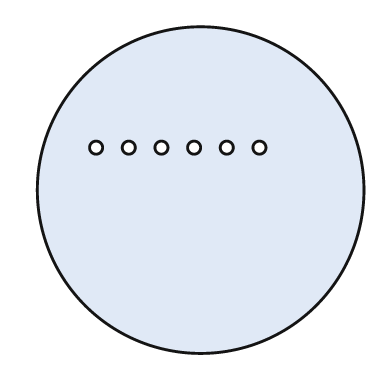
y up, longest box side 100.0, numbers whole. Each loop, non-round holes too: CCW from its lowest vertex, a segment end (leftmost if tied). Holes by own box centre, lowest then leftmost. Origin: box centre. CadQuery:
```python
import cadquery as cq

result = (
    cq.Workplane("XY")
    .moveTo(0.0, 0.0)
    .circle(50.0)
    .moveTo(-32.0, 13.0)
    .circle(2.0)
    .moveTo(-22.0, 13.0)
    .circle(2.0)
    .moveTo(-12.0, 13.0)
    .circle(2.0)
    .moveTo(-2.0, 13.0)
    .circle(2.0)
    .moveTo(8.0, 13.0)
    .circle(2.0)
    .moveTo(18.0, 13.0)
    .circle(2.0)
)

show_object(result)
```